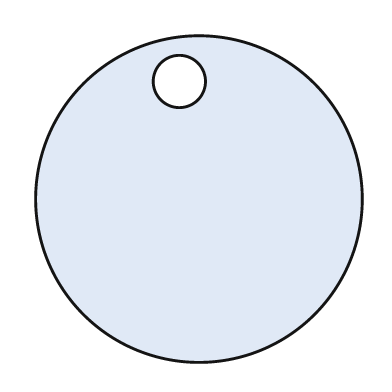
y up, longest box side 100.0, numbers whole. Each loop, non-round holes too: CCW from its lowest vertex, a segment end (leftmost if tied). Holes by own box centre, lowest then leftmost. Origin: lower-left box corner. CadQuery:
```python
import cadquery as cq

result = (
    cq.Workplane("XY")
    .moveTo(50.0, 50.0)
    .circle(50.0)
    .moveTo(44.0, 86.0)
    .circle(8.0)
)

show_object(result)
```